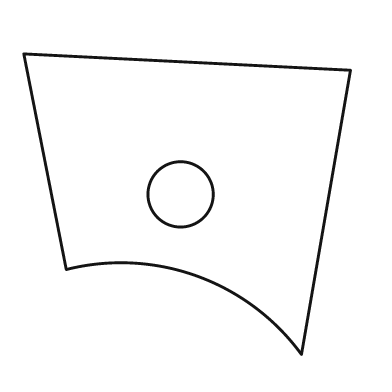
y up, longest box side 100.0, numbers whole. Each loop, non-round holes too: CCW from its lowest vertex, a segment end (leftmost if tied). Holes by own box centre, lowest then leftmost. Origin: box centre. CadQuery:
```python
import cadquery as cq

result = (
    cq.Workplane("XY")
    .moveTo(35.0, -46.0)
    .lineTo(50.0, 41.0)
    .lineTo(-50.0, 46.0)
    .lineTo(-37.0, -20.0)
    .threePointArc((3.0, -22.0), (35.0, -46.0))
    .close()
    .moveTo(-2.0, 3.0)
    .circle(10.0)
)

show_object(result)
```